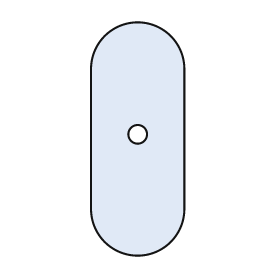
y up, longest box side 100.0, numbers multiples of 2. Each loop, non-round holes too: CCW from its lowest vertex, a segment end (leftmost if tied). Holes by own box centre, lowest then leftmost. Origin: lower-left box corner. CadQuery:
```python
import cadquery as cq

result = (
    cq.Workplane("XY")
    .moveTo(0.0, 20.0)
    .threePointArc((20.0, 0.0), (40.0, 20.0))
    .lineTo(40.0, 80.0)
    .threePointArc((20.0, 100.0), (0.0, 80.0))
    .close()
    .moveTo(20.0, 52.0)
    .circle(4.0)
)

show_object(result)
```